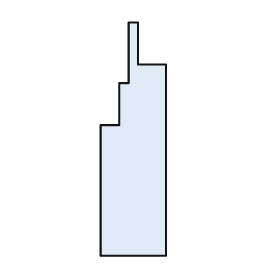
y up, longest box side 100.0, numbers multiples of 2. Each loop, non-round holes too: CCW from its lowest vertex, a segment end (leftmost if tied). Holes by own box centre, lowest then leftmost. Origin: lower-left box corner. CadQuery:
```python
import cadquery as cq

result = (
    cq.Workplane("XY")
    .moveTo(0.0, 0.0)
    .lineTo(28.0, 0.0)
    .lineTo(28.0, 82.0)
    .lineTo(16.0, 82.0)
    .lineTo(16.0, 100.0)
    .lineTo(12.0, 100.0)
    .lineTo(12.0, 74.0)
    .lineTo(8.0, 74.0)
    .lineTo(8.0, 56.0)
    .lineTo(0.0, 56.0)
    .close()
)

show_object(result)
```